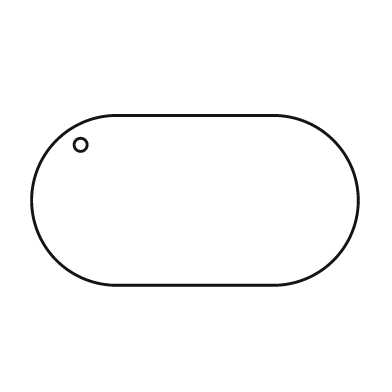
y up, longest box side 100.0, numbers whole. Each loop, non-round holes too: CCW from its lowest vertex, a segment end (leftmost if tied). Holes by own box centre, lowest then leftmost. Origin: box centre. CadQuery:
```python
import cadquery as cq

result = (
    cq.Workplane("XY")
    .moveTo(-24.0, -26.0)
    .lineTo(24.0, -26.0)
    .threePointArc((50.0, 0.0), (24.0, 26.0))
    .lineTo(-24.0, 26.0)
    .threePointArc((-50.0, 0.0), (-24.0, -26.0))
    .close()
    .moveTo(-35.0, 17.0)
    .circle(2.0)
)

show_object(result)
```